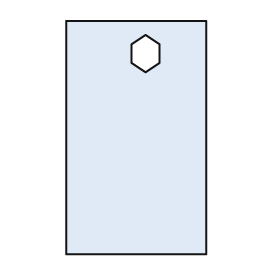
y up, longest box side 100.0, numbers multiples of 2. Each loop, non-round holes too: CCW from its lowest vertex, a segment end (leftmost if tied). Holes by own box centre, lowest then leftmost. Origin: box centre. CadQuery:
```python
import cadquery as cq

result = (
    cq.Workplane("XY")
    .moveTo(-30.0, -50.0)
    .lineTo(30.0, -50.0)
    .lineTo(30.0, 50.0)
    .lineTo(-30.0, 50.0)
    .close()
    .moveTo(4.0, 28.0)
    .lineTo(10.0, 32.0)
    .lineTo(10.0, 40.0)
    .lineTo(4.0, 44.0)
    .lineTo(-2.0, 40.0)
    .lineTo(-2.0, 32.0)
    .close()
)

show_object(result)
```